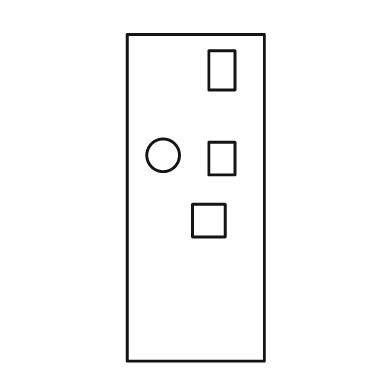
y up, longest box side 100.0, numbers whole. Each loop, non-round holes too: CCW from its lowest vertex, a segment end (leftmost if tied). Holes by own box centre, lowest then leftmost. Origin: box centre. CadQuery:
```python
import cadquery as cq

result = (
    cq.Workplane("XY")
    .moveTo(-21.0, -50.0)
    .lineTo(21.0, -50.0)
    .lineTo(21.0, 50.0)
    .lineTo(-21.0, 50.0)
    .close()
    .moveTo(-1.0, -12.0)
    .lineTo(9.0, -12.0)
    .lineTo(9.0, -2.0)
    .lineTo(-1.0, -2.0)
    .close()
    .moveTo(4.0, 7.0)
    .lineTo(12.0, 7.0)
    .lineTo(12.0, 17.0)
    .lineTo(4.0, 17.0)
    .close()
    .moveTo(-10.0, 13.0)
    .circle(5.0)
    .moveTo(4.0, 33.0)
    .lineTo(12.0, 33.0)
    .lineTo(12.0, 45.0)
    .lineTo(4.0, 45.0)
    .close()
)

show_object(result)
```